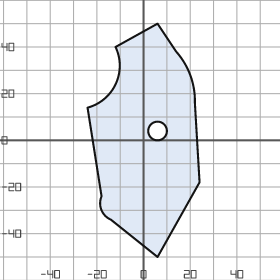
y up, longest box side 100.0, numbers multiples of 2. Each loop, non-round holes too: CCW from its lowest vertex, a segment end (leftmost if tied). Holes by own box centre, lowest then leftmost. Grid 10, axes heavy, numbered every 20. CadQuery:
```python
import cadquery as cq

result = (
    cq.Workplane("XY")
    .moveTo(6.0, -50.0)
    .lineTo(24.0, -18.0)
    .lineTo(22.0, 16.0)
    .threePointArc((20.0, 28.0), (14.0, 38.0))
    .lineTo(6.0, 50.0)
    .lineTo(-12.0, 40.0)
    .threePointArc((-12.0, 24.0), (-24.0, 14.0))
    .lineTo(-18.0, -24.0)
    .threePointArc((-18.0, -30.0), (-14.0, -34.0))
    .close()
    .moveTo(6.0, 4.0)
    .circle(4.0)
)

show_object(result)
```